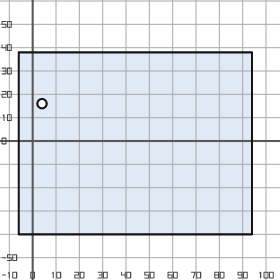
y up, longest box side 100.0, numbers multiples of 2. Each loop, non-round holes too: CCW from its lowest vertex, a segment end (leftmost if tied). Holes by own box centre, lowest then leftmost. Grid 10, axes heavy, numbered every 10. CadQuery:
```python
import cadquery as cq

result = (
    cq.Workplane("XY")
    .moveTo(-6.0, -40.0)
    .lineTo(94.0, -40.0)
    .lineTo(94.0, 38.0)
    .lineTo(-6.0, 38.0)
    .close()
    .moveTo(4.0, 16.0)
    .circle(2.0)
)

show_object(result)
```